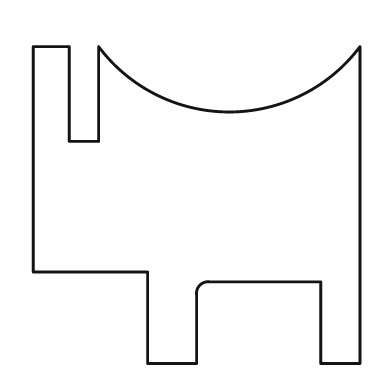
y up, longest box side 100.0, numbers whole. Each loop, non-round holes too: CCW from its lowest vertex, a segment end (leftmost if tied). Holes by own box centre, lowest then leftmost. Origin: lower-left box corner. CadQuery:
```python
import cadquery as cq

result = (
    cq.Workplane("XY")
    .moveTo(35.0, 0.0)
    .lineTo(50.0, 0.0)
    .lineTo(50.0, 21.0)
    .threePointArc((51.0, 24.0), (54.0, 25.0))
    .lineTo(88.0, 25.0)
    .lineTo(88.0, 0.0)
    .lineTo(100.0, 0.0)
    .lineTo(100.0, 97.0)
    .threePointArc((60.0, 77.0), (20.0, 97.0))
    .lineTo(20.0, 68.0)
    .lineTo(11.0, 68.0)
    .lineTo(11.0, 97.0)
    .lineTo(0.0, 97.0)
    .lineTo(0.0, 28.0)
    .lineTo(35.0, 28.0)
    .close()
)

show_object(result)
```